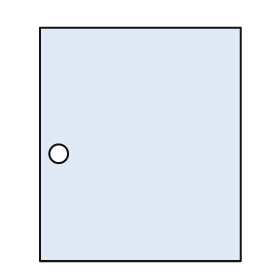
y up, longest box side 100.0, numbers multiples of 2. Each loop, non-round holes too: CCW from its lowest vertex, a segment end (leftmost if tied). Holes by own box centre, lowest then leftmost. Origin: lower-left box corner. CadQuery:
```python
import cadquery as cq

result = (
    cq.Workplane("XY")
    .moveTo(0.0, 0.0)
    .lineTo(86.0, 0.0)
    .lineTo(86.0, 100.0)
    .lineTo(0.0, 100.0)
    .close()
    .moveTo(8.0, 46.0)
    .circle(4.0)
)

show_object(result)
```